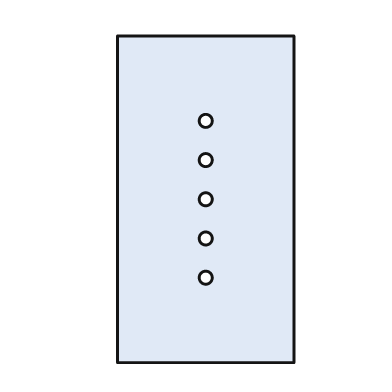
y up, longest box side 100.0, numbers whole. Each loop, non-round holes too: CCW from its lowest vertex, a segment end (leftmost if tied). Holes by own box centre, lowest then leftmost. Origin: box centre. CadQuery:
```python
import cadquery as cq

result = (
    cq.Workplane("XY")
    .moveTo(-27.0, -50.0)
    .lineTo(27.0, -50.0)
    .lineTo(27.0, 50.0)
    .lineTo(-27.0, 50.0)
    .close()
    .moveTo(0.0, -24.0)
    .circle(2.0)
    .moveTo(0.0, -12.0)
    .circle(2.0)
    .moveTo(0.0, 0.0)
    .circle(2.0)
    .moveTo(0.0, 12.0)
    .circle(2.0)
    .moveTo(0.0, 24.0)
    .circle(2.0)
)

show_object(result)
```